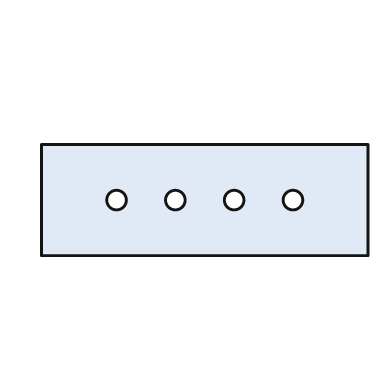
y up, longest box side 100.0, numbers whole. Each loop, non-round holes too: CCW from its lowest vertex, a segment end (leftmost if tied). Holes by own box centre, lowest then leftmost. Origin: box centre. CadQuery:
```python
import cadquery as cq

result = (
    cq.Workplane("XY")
    .moveTo(-50.0, -17.0)
    .lineTo(50.0, -17.0)
    .lineTo(50.0, 17.0)
    .lineTo(-50.0, 17.0)
    .close()
    .moveTo(-27.0, 0.0)
    .circle(3.0)
    .moveTo(-9.0, 0.0)
    .circle(3.0)
    .moveTo(9.0, 0.0)
    .circle(3.0)
    .moveTo(27.0, 0.0)
    .circle(3.0)
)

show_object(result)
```